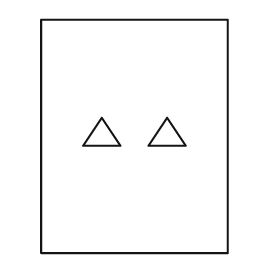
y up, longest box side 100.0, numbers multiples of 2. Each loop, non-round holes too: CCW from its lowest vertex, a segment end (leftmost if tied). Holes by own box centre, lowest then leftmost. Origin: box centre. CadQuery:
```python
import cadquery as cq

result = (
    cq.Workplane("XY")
    .moveTo(-40.0, -50.0)
    .lineTo(40.0, -50.0)
    .lineTo(40.0, 50.0)
    .lineTo(-40.0, 50.0)
    .close()
    .moveTo(-22.0, -4.0)
    .lineTo(-6.0, -4.0)
    .lineTo(-14.0, 8.0)
    .close()
    .moveTo(6.0, -4.0)
    .lineTo(22.0, -4.0)
    .lineTo(14.0, 8.0)
    .close()
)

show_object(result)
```